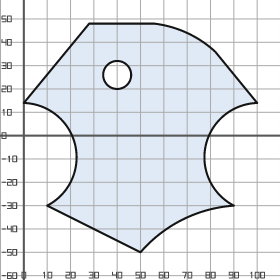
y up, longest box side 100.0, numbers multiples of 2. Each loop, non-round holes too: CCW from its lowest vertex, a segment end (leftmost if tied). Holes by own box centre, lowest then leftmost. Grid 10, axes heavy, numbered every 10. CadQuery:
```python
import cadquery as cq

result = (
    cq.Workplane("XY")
    .moveTo(50.0, -50.0)
    .threePointArc((68.0, -36.0), (90.0, -30.0))
    .threePointArc((78.0, -4.0), (100.0, 14.0))
    .lineTo(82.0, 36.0)
    .threePointArc((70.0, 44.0), (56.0, 48.0))
    .lineTo(28.0, 48.0)
    .lineTo(0.0, 14.0)
    .threePointArc((22.0, -4.0), (10.0, -30.0))
    .close()
    .moveTo(40.0, 26.0)
    .circle(6.0)
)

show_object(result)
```